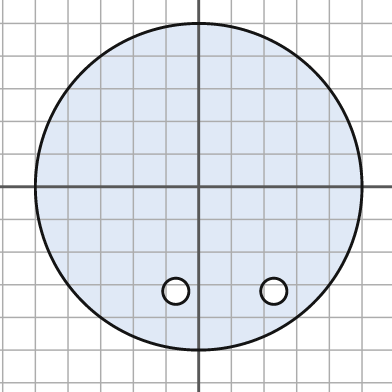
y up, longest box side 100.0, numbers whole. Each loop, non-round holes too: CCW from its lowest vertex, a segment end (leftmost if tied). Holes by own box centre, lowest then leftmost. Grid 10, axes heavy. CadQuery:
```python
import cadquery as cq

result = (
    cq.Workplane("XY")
    .moveTo(0.0, 0.0)
    .circle(50.0)
    .moveTo(-7.0, -32.0)
    .circle(4.0)
    .moveTo(23.0, -32.0)
    .circle(4.0)
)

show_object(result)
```